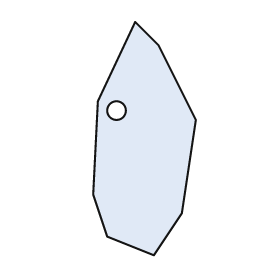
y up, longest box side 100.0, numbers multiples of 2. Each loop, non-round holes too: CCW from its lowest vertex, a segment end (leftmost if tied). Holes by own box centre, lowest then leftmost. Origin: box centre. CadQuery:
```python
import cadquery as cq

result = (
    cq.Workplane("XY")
    .moveTo(4.0, -50.0)
    .lineTo(16.0, -32.0)
    .lineTo(22.0, 8.0)
    .lineTo(6.0, 40.0)
    .lineTo(-4.0, 50.0)
    .lineTo(-20.0, 16.0)
    .lineTo(-22.0, -24.0)
    .lineTo(-16.0, -42.0)
    .close()
    .moveTo(-12.0, 12.0)
    .circle(4.0)
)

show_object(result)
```